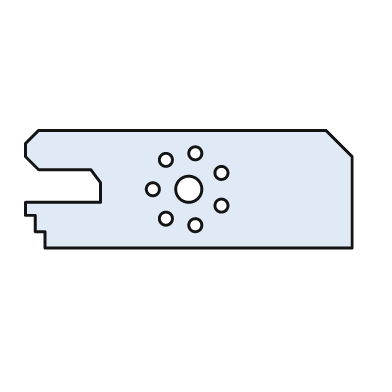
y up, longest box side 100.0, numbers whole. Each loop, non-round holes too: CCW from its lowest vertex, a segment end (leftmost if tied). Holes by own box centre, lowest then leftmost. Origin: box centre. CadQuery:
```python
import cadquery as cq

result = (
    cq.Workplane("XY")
    .moveTo(-44.0, -18.0)
    .lineTo(50.0, -18.0)
    .lineTo(50.0, 10.0)
    .lineTo(42.0, 18.0)
    .lineTo(-46.0, 18.0)
    .lineTo(-50.0, 14.0)
    .lineTo(-50.0, 10.0)
    .lineTo(-46.0, 6.0)
    .lineTo(-30.0, 6.0)
    .lineTo(-27.0, 2.0)
    .lineTo(-27.0, -4.0)
    .lineTo(-50.0, -4.0)
    .lineTo(-50.0, -8.0)
    .lineTo(-47.0, -8.0)
    .lineTo(-47.0, -13.0)
    .lineTo(-44.0, -13.0)
    .close()
    .moveTo(2.0, -11.0)
    .circle(2.0)
    .moveTo(-7.0, -9.0)
    .circle(2.0)
    .moveTo(10.0, -5.0)
    .circle(2.0)
    .moveTo(-11.0, 0.0)
    .circle(2.0)
    .moveTo(0.0, 0.0)
    .circle(4.0)
    .moveTo(10.0, 5.0)
    .circle(2.0)
    .moveTo(-7.0, 9.0)
    .circle(2.0)
    .moveTo(2.0, 11.0)
    .circle(2.0)
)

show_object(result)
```